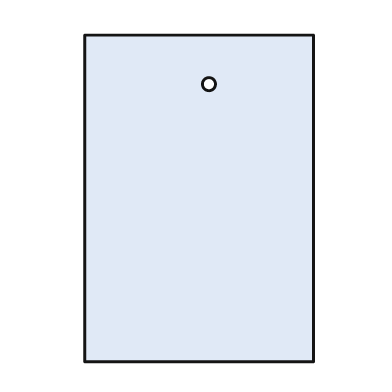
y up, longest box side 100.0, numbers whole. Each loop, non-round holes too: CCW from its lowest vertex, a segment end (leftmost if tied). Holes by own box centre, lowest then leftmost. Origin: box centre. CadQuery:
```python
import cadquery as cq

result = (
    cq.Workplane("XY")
    .moveTo(-35.0, -50.0)
    .lineTo(35.0, -50.0)
    .lineTo(35.0, 50.0)
    .lineTo(-35.0, 50.0)
    .close()
    .moveTo(3.0, 35.0)
    .circle(2.0)
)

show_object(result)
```